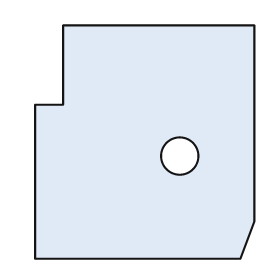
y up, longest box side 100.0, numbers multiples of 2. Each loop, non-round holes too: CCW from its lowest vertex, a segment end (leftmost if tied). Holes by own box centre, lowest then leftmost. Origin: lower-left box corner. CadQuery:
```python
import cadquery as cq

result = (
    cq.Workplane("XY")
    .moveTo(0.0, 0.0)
    .lineTo(88.0, 0.0)
    .lineTo(94.0, 16.0)
    .lineTo(94.0, 100.0)
    .lineTo(12.0, 100.0)
    .lineTo(12.0, 66.0)
    .lineTo(0.0, 66.0)
    .close()
    .moveTo(62.0, 44.0)
    .circle(8.0)
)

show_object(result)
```